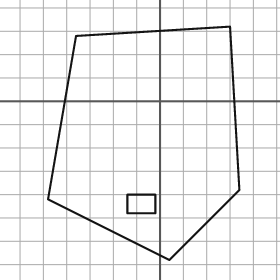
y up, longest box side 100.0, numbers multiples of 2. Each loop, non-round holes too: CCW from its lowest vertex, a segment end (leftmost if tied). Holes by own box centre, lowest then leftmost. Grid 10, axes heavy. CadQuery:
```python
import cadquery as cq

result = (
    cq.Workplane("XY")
    .moveTo(4.0, -68.0)
    .lineTo(34.0, -38.0)
    .lineTo(30.0, 32.0)
    .lineTo(-36.0, 28.0)
    .lineTo(-48.0, -42.0)
    .close()
    .moveTo(-14.0, -48.0)
    .lineTo(-2.0, -48.0)
    .lineTo(-2.0, -40.0)
    .lineTo(-14.0, -40.0)
    .close()
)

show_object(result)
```